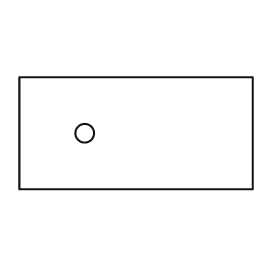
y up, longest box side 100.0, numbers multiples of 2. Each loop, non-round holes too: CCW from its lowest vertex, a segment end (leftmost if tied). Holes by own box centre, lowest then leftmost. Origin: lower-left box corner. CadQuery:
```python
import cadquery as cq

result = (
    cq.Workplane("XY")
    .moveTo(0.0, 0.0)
    .lineTo(100.0, 0.0)
    .lineTo(100.0, 48.0)
    .lineTo(0.0, 48.0)
    .close()
    .moveTo(28.0, 24.0)
    .circle(4.0)
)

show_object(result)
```